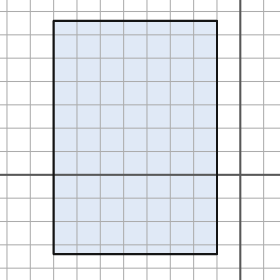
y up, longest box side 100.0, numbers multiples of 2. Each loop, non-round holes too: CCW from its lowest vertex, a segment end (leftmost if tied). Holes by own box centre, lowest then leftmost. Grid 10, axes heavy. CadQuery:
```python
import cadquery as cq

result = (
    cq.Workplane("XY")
    .moveTo(-80.0, -34.0)
    .lineTo(-10.0, -34.0)
    .lineTo(-10.0, 66.0)
    .lineTo(-80.0, 66.0)
    .close()
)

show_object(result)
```